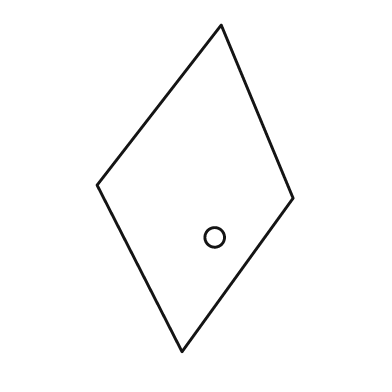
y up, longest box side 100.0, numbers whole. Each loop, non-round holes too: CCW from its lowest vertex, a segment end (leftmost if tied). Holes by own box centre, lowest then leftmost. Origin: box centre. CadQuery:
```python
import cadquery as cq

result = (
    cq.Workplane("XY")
    .moveTo(-4.0, -50.0)
    .lineTo(30.0, -3.0)
    .lineTo(8.0, 50.0)
    .lineTo(-30.0, 1.0)
    .close()
    .moveTo(6.0, -15.0)
    .circle(3.0)
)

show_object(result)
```